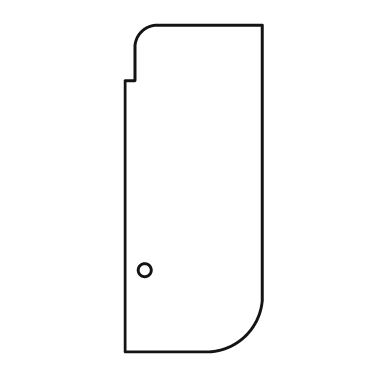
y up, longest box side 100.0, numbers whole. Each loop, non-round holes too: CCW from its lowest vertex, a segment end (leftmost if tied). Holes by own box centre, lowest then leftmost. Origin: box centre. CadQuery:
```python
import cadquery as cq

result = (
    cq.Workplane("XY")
    .moveTo(-21.0, -50.0)
    .lineTo(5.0, -50.0)
    .threePointArc((16.0, -45.0), (21.0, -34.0))
    .lineTo(21.0, 50.0)
    .lineTo(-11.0, 50.0)
    .threePointArc((-16.0, 48.0), (-18.0, 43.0))
    .lineTo(-18.0, 33.0)
    .lineTo(-21.0, 33.0)
    .close()
    .moveTo(-15.0, -25.0)
    .circle(2.0)
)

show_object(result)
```